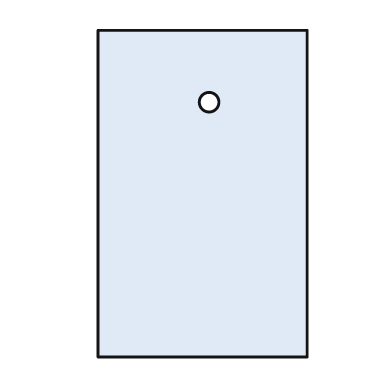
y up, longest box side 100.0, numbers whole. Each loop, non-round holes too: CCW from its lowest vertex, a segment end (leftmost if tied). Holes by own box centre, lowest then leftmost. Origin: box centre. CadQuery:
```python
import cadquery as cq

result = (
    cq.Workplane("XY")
    .moveTo(-32.0, -50.0)
    .lineTo(32.0, -50.0)
    .lineTo(32.0, 50.0)
    .lineTo(-32.0, 50.0)
    .close()
    .moveTo(2.0, 28.0)
    .circle(3.0)
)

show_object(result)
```